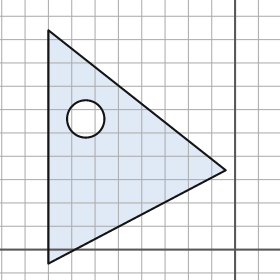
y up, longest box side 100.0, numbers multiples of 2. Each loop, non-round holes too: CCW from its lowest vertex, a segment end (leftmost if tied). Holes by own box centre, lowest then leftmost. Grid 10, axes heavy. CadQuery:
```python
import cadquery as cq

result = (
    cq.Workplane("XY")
    .moveTo(-80.0, -6.0)
    .lineTo(-4.0, 34.0)
    .lineTo(-80.0, 94.0)
    .close()
    .moveTo(-64.0, 56.0)
    .circle(8.0)
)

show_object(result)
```